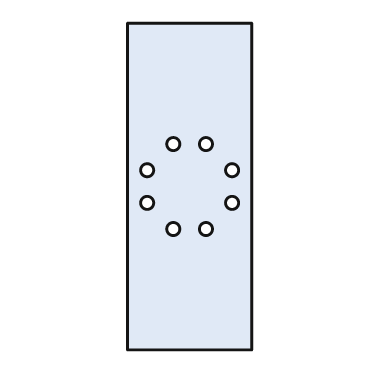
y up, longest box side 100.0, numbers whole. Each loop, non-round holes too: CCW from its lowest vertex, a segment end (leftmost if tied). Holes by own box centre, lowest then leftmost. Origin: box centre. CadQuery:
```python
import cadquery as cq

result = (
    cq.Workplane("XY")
    .moveTo(-19.0, -50.0)
    .lineTo(19.0, -50.0)
    .lineTo(19.0, 50.0)
    .lineTo(-19.0, 50.0)
    .close()
    .moveTo(-5.0, -13.0)
    .circle(2.0)
    .moveTo(5.0, -13.0)
    .circle(2.0)
    .moveTo(-13.0, -5.0)
    .circle(2.0)
    .moveTo(13.0, -5.0)
    .circle(2.0)
    .moveTo(-13.0, 5.0)
    .circle(2.0)
    .moveTo(13.0, 5.0)
    .circle(2.0)
    .moveTo(-5.0, 13.0)
    .circle(2.0)
    .moveTo(5.0, 13.0)
    .circle(2.0)
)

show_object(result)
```